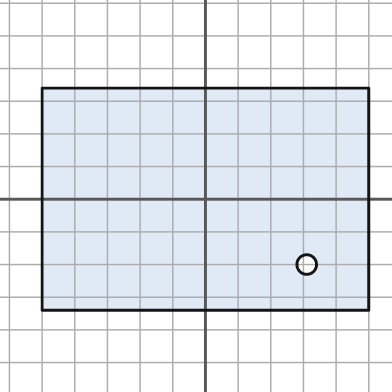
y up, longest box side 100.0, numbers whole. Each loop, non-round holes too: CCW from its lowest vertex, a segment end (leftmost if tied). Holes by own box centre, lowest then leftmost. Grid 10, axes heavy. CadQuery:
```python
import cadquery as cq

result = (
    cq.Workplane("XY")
    .moveTo(-50.0, -34.0)
    .lineTo(50.0, -34.0)
    .lineTo(50.0, 34.0)
    .lineTo(-50.0, 34.0)
    .close()
    .moveTo(31.0, -20.0)
    .circle(3.0)
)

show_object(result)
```